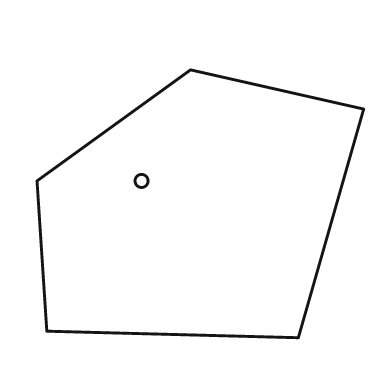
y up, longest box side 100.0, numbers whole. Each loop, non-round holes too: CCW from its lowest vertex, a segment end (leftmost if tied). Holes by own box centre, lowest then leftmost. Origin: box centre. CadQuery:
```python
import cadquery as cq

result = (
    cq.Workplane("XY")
    .moveTo(30.0, -41.0)
    .lineTo(50.0, 29.0)
    .lineTo(-3.0, 41.0)
    .lineTo(-50.0, 7.0)
    .lineTo(-47.0, -39.0)
    .close()
    .moveTo(-18.0, 7.0)
    .circle(2.0)
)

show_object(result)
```